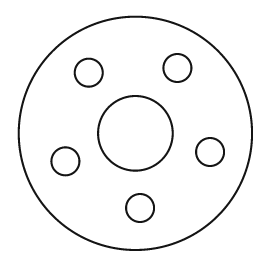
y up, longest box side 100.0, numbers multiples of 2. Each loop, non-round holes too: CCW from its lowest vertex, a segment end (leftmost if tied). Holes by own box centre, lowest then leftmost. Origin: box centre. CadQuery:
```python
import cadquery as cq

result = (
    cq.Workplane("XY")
    .moveTo(0.0, 0.0)
    .circle(50.0)
    .moveTo(2.0, -32.0)
    .circle(6.0)
    .moveTo(-30.0, -12.0)
    .circle(6.0)
    .moveTo(32.0, -8.0)
    .circle(6.0)
    .moveTo(0.0, 0.0)
    .circle(16.0)
    .moveTo(-20.0, 26.0)
    .circle(6.0)
    .moveTo(18.0, 28.0)
    .circle(6.0)
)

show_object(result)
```